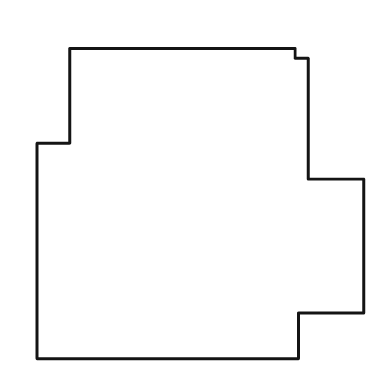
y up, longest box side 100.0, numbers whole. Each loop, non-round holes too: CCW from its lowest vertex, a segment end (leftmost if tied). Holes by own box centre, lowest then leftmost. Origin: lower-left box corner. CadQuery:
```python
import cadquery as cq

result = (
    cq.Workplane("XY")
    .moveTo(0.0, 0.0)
    .lineTo(80.0, 0.0)
    .lineTo(80.0, 14.0)
    .lineTo(100.0, 14.0)
    .lineTo(100.0, 55.0)
    .lineTo(83.0, 55.0)
    .lineTo(83.0, 92.0)
    .lineTo(79.0, 92.0)
    .lineTo(79.0, 95.0)
    .lineTo(10.0, 95.0)
    .lineTo(10.0, 66.0)
    .lineTo(0.0, 66.0)
    .close()
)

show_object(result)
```